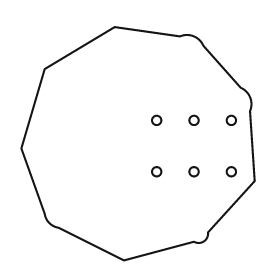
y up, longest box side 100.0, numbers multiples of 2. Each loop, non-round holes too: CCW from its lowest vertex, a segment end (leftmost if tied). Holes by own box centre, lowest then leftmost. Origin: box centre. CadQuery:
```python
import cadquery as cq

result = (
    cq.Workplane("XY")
    .moveTo(-6.0, -50.0)
    .lineTo(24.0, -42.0)
    .threePointArc((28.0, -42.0), (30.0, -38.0))
    .lineTo(50.0, -16.0)
    .lineTo(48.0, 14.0)
    .threePointArc((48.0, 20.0), (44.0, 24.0))
    .lineTo(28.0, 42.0)
    .threePointArc((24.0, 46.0), (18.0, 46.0))
    .lineTo(-10.0, 50.0)
    .lineTo(-40.0, 32.0)
    .lineTo(-50.0, -2.0)
    .lineTo(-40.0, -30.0)
    .threePointArc((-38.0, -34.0), (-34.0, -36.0))
    .close()
    .moveTo(8.0, -12.0)
    .circle(2.0)
    .moveTo(24.0, -12.0)
    .circle(2.0)
    .moveTo(40.0, -12.0)
    .circle(2.0)
    .moveTo(8.0, 10.0)
    .circle(2.0)
    .moveTo(24.0, 10.0)
    .circle(2.0)
    .moveTo(40.0, 10.0)
    .circle(2.0)
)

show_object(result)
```